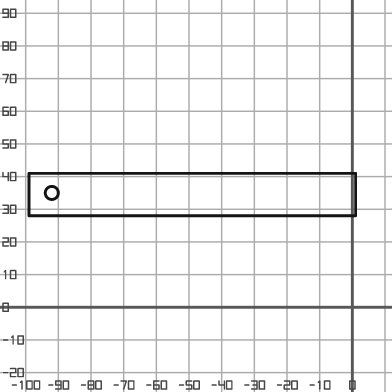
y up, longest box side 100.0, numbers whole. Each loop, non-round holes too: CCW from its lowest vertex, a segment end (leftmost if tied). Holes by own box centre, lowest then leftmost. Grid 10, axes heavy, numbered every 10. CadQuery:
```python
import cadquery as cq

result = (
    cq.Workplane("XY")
    .moveTo(-99.0, 28.0)
    .lineTo(1.0, 28.0)
    .lineTo(1.0, 41.0)
    .lineTo(-99.0, 41.0)
    .close()
    .moveTo(-92.0, 35.0)
    .circle(2.0)
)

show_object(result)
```